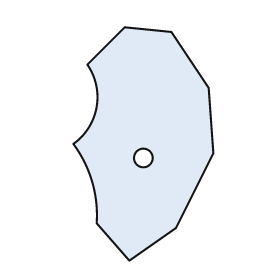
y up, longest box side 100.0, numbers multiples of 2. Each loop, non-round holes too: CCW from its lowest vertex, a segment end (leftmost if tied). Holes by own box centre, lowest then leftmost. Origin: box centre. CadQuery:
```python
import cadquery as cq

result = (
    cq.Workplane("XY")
    .moveTo(-6.0, -50.0)
    .lineTo(14.0, -36.0)
    .lineTo(30.0, -4.0)
    .lineTo(28.0, 24.0)
    .lineTo(12.0, 48.0)
    .lineTo(-8.0, 50.0)
    .lineTo(-24.0, 34.0)
    .threePointArc((-20.0, 16.0), (-30.0, 0.0))
    .threePointArc((-22.0, -16.0), (-20.0, -34.0))
    .close()
    .moveTo(0.0, -6.0)
    .circle(4.0)
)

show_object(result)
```